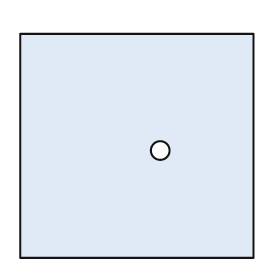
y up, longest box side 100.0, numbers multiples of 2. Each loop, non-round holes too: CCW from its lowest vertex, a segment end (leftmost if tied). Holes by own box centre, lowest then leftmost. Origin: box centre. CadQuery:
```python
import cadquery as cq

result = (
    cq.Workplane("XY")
    .moveTo(-50.0, -48.0)
    .lineTo(50.0, -48.0)
    .lineTo(50.0, 48.0)
    .lineTo(-50.0, 48.0)
    .close()
    .moveTo(10.0, -2.0)
    .circle(4.0)
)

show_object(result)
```